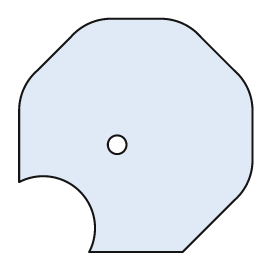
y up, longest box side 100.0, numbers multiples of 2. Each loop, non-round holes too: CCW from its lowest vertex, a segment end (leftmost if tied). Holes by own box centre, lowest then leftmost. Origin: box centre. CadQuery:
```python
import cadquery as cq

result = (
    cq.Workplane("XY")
    .moveTo(-20.0, -50.0)
    .lineTo(20.0, -50.0)
    .lineTo(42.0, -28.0)
    .threePointArc((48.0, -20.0), (50.0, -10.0))
    .lineTo(50.0, 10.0)
    .threePointArc((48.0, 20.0), (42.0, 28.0))
    .lineTo(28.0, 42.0)
    .threePointArc((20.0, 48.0), (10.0, 50.0))
    .lineTo(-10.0, 50.0)
    .threePointArc((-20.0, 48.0), (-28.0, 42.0))
    .lineTo(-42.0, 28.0)
    .threePointArc((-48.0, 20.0), (-50.0, 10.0))
    .lineTo(-50.0, -20.0)
    .threePointArc((-24.0, -24.0), (-20.0, -50.0))
    .close()
    .moveTo(-8.0, -4.0)
    .circle(4.0)
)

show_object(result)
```